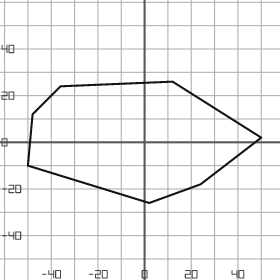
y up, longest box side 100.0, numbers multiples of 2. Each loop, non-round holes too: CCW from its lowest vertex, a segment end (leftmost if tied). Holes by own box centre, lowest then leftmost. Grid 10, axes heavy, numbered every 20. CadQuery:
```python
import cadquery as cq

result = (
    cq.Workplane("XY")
    .moveTo(2.0, -26.0)
    .lineTo(24.0, -18.0)
    .lineTo(50.0, 2.0)
    .lineTo(12.0, 26.0)
    .lineTo(-36.0, 24.0)
    .lineTo(-48.0, 12.0)
    .lineTo(-50.0, -10.0)
    .close()
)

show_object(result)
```